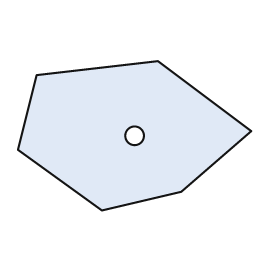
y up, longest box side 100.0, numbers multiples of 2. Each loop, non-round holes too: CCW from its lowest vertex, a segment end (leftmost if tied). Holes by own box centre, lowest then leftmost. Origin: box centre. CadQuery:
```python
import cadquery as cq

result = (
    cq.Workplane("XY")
    .moveTo(-14.0, -32.0)
    .lineTo(20.0, -24.0)
    .lineTo(50.0, 2.0)
    .lineTo(10.0, 32.0)
    .lineTo(-42.0, 26.0)
    .lineTo(-50.0, -6.0)
    .close()
    .moveTo(0.0, 0.0)
    .circle(4.0)
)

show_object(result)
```